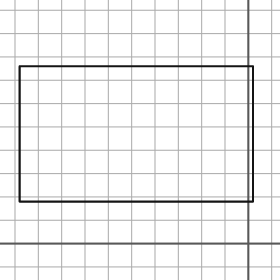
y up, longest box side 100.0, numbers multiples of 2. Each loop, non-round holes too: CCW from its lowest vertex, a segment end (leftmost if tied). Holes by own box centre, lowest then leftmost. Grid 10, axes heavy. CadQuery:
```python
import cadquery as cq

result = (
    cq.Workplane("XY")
    .moveTo(-98.0, 18.0)
    .lineTo(2.0, 18.0)
    .lineTo(2.0, 76.0)
    .lineTo(-98.0, 76.0)
    .close()
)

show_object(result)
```